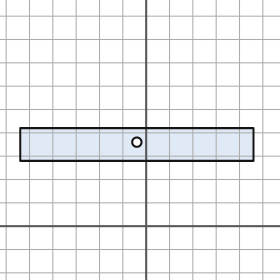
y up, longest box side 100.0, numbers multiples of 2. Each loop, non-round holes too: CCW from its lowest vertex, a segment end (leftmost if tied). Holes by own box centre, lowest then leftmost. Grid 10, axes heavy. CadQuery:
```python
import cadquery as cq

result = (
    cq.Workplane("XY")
    .moveTo(-54.0, 28.0)
    .lineTo(46.0, 28.0)
    .lineTo(46.0, 42.0)
    .lineTo(-54.0, 42.0)
    .close()
    .moveTo(-4.0, 36.0)
    .circle(2.0)
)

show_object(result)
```